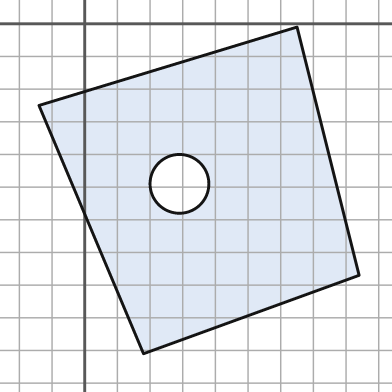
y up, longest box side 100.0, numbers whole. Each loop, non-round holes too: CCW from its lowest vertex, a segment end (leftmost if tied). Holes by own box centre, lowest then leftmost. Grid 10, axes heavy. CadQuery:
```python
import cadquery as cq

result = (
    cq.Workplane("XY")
    .moveTo(18.0, -101.0)
    .lineTo(84.0, -77.0)
    .lineTo(65.0, -1.0)
    .lineTo(-14.0, -25.0)
    .close()
    .moveTo(29.0, -49.0)
    .circle(9.0)
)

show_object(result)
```